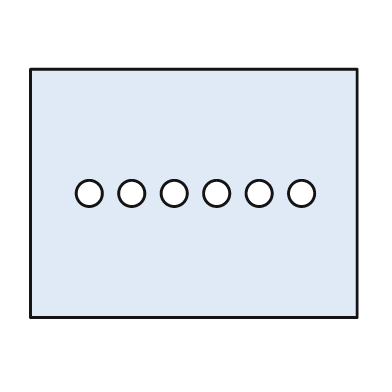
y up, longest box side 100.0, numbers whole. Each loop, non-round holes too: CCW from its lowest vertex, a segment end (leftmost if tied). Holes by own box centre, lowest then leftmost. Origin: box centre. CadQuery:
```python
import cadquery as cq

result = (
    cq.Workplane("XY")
    .moveTo(-50.0, -38.0)
    .lineTo(50.0, -38.0)
    .lineTo(50.0, 38.0)
    .lineTo(-50.0, 38.0)
    .close()
    .moveTo(-32.0, 0.0)
    .circle(4.0)
    .moveTo(-19.0, 0.0)
    .circle(4.0)
    .moveTo(-6.0, 0.0)
    .circle(4.0)
    .moveTo(7.0, 0.0)
    .circle(4.0)
    .moveTo(20.0, 0.0)
    .circle(4.0)
    .moveTo(33.0, 0.0)
    .circle(4.0)
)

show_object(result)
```